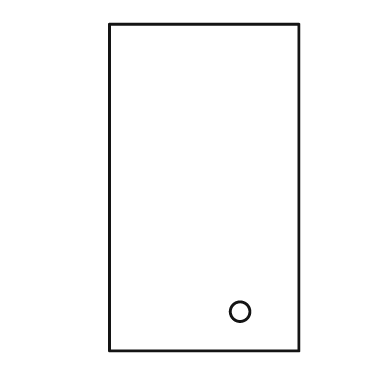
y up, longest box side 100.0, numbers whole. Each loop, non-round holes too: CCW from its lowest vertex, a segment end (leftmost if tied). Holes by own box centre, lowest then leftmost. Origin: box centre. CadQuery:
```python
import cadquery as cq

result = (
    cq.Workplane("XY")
    .moveTo(-29.0, -50.0)
    .lineTo(29.0, -50.0)
    .lineTo(29.0, 50.0)
    .lineTo(-29.0, 50.0)
    .close()
    .moveTo(11.0, -38.0)
    .circle(3.0)
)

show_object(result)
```